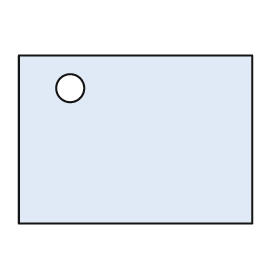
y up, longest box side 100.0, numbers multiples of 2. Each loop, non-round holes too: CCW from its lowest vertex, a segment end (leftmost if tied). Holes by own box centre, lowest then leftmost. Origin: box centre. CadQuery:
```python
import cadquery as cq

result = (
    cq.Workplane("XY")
    .moveTo(-50.0, -36.0)
    .lineTo(50.0, -36.0)
    .lineTo(50.0, 36.0)
    .lineTo(-50.0, 36.0)
    .close()
    .moveTo(-28.0, 22.0)
    .circle(6.0)
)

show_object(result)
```